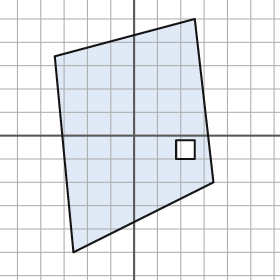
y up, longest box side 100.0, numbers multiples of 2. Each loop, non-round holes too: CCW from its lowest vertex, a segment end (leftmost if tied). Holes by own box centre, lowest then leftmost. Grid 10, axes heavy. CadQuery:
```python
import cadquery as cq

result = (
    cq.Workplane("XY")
    .moveTo(-26.0, -50.0)
    .lineTo(34.0, -20.0)
    .lineTo(26.0, 50.0)
    .lineTo(-34.0, 34.0)
    .close()
    .moveTo(18.0, -10.0)
    .lineTo(26.0, -10.0)
    .lineTo(26.0, -2.0)
    .lineTo(18.0, -2.0)
    .close()
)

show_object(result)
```